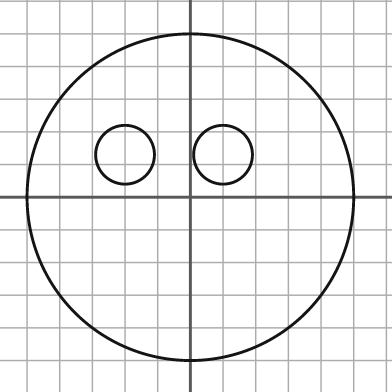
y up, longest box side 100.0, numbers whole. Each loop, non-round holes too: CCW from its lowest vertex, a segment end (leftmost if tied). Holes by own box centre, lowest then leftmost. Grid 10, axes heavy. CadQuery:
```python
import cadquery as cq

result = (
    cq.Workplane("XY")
    .moveTo(0.0, 0.0)
    .circle(50.0)
    .moveTo(-20.0, 13.0)
    .circle(9.0)
    .moveTo(10.0, 13.0)
    .circle(9.0)
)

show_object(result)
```